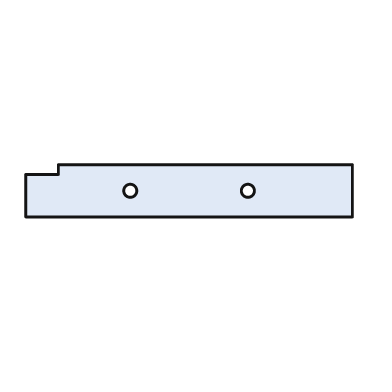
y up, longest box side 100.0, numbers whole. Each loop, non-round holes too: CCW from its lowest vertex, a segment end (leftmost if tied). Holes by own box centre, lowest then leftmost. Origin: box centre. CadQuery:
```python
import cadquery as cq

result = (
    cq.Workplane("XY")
    .moveTo(-50.0, -8.0)
    .lineTo(50.0, -8.0)
    .lineTo(50.0, 8.0)
    .lineTo(-40.0, 8.0)
    .lineTo(-40.0, 5.0)
    .lineTo(-50.0, 5.0)
    .close()
    .moveTo(-18.0, 0.0)
    .circle(2.0)
    .moveTo(18.0, 0.0)
    .circle(2.0)
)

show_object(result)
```